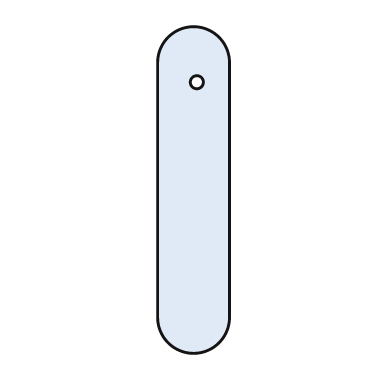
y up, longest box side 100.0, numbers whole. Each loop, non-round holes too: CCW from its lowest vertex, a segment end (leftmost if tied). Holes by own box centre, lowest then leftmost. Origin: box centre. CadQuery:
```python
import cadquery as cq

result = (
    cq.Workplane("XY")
    .moveTo(-11.0, -39.0)
    .threePointArc((0.0, -50.0), (11.0, -39.0))
    .lineTo(11.0, 39.0)
    .threePointArc((0.0, 50.0), (-11.0, 39.0))
    .close()
    .moveTo(1.0, 33.0)
    .circle(2.0)
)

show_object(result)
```